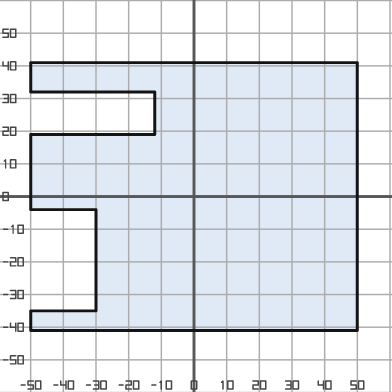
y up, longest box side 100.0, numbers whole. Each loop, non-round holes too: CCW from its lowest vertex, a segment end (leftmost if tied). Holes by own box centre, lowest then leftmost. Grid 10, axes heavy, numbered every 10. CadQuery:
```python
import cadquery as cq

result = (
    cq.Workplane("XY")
    .moveTo(-50.0, -41.0)
    .lineTo(50.0, -41.0)
    .lineTo(50.0, 41.0)
    .lineTo(-50.0, 41.0)
    .lineTo(-50.0, 32.0)
    .lineTo(-12.0, 32.0)
    .lineTo(-12.0, 19.0)
    .lineTo(-50.0, 19.0)
    .lineTo(-50.0, -4.0)
    .lineTo(-30.0, -4.0)
    .lineTo(-30.0, -35.0)
    .lineTo(-50.0, -35.0)
    .close()
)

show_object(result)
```